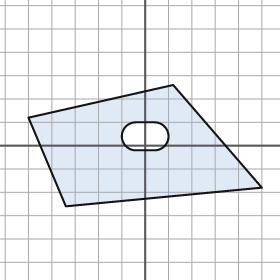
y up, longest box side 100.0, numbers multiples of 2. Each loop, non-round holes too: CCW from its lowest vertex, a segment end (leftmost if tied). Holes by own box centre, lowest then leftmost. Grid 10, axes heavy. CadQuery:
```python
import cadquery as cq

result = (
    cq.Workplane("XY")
    .moveTo(-34.0, -26.0)
    .lineTo(50.0, -18.0)
    .lineTo(12.0, 26.0)
    .lineTo(-50.0, 12.0)
    .close()
    .moveTo(-4.0, -2.0)
    .lineTo(4.0, -2.0)
    .threePointArc((10.0, 4.0), (4.0, 10.0))
    .lineTo(-4.0, 10.0)
    .threePointArc((-10.0, 4.0), (-4.0, -2.0))
    .close()
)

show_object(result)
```